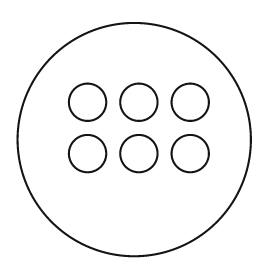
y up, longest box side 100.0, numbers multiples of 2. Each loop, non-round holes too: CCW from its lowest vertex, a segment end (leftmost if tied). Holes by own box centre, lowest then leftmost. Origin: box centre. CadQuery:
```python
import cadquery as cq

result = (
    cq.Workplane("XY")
    .moveTo(0.0, 0.0)
    .circle(50.0)
    .moveTo(-20.0, -6.0)
    .circle(8.0)
    .moveTo(2.0, -6.0)
    .circle(8.0)
    .moveTo(24.0, -6.0)
    .circle(8.0)
    .moveTo(-20.0, 16.0)
    .circle(8.0)
    .moveTo(2.0, 16.0)
    .circle(8.0)
    .moveTo(24.0, 16.0)
    .circle(8.0)
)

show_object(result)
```